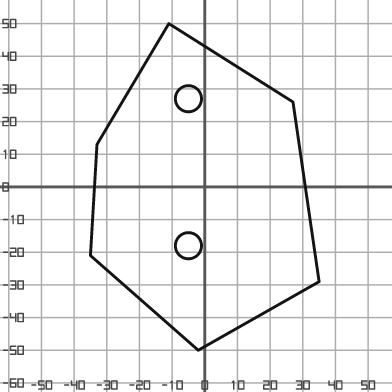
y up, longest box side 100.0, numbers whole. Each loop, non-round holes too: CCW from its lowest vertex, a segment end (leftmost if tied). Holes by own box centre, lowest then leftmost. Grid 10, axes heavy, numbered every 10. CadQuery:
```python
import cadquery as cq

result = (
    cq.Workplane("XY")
    .moveTo(-2.0, -50.0)
    .lineTo(35.0, -29.0)
    .lineTo(27.0, 26.0)
    .lineTo(-11.0, 50.0)
    .lineTo(-33.0, 13.0)
    .lineTo(-35.0, -21.0)
    .close()
    .moveTo(-5.0, -18.0)
    .circle(4.0)
    .moveTo(-5.0, 27.0)
    .circle(4.0)
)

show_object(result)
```